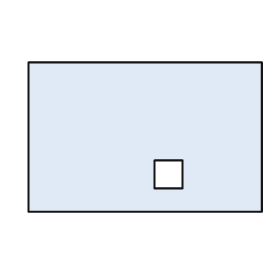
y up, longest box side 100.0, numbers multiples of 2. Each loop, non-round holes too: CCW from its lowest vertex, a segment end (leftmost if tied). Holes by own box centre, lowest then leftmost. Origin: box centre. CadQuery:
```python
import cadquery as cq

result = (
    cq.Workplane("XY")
    .moveTo(-50.0, -32.0)
    .lineTo(50.0, -32.0)
    .lineTo(50.0, 32.0)
    .lineTo(-50.0, 32.0)
    .close()
    .moveTo(4.0, -22.0)
    .lineTo(16.0, -22.0)
    .lineTo(16.0, -10.0)
    .lineTo(4.0, -10.0)
    .close()
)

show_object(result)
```